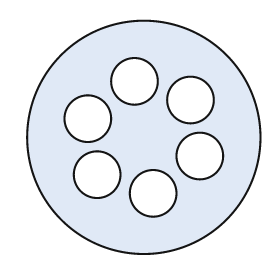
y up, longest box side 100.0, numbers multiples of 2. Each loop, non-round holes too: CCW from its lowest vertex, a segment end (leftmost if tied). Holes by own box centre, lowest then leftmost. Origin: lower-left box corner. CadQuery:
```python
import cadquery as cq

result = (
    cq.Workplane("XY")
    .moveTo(50.0, 50.0)
    .circle(50.0)
    .moveTo(54.0, 26.0)
    .circle(10.0)
    .moveTo(30.0, 34.0)
    .circle(10.0)
    .moveTo(74.0, 42.0)
    .circle(10.0)
    .moveTo(26.0, 58.0)
    .circle(10.0)
    .moveTo(70.0, 66.0)
    .circle(10.0)
    .moveTo(46.0, 74.0)
    .circle(10.0)
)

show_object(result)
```